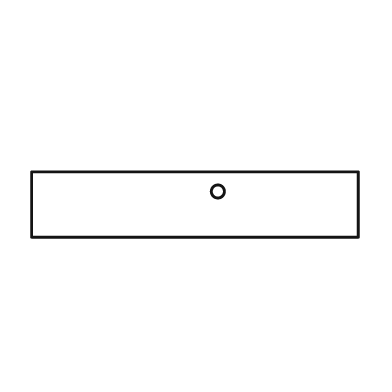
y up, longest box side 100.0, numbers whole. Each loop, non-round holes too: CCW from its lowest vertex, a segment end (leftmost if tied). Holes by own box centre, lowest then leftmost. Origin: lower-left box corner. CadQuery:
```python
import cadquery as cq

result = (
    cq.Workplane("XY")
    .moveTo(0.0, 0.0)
    .lineTo(100.0, 0.0)
    .lineTo(100.0, 20.0)
    .lineTo(0.0, 20.0)
    .close()
    .moveTo(57.0, 14.0)
    .circle(2.0)
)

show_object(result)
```